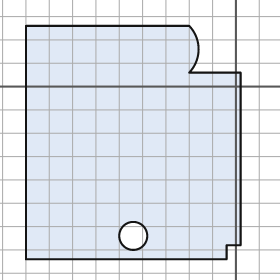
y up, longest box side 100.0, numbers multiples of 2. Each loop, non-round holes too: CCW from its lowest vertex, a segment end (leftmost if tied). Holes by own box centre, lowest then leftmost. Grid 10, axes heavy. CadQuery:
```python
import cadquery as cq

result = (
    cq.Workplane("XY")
    .moveTo(-90.0, -74.0)
    .lineTo(-4.0, -74.0)
    .lineTo(-4.0, -68.0)
    .lineTo(2.0, -68.0)
    .lineTo(2.0, 6.0)
    .lineTo(-20.0, 6.0)
    .threePointArc((-16.0, 16.0), (-20.0, 26.0))
    .lineTo(-90.0, 26.0)
    .close()
    .moveTo(-44.0, -64.0)
    .circle(6.0)
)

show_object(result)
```